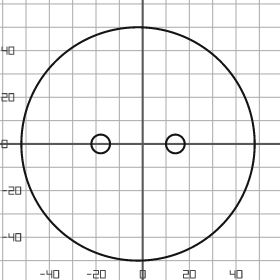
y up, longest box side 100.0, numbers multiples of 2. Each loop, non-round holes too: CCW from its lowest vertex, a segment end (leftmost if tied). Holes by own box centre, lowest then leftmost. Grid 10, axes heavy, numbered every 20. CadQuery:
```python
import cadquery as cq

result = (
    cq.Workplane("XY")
    .moveTo(-2.0, 0.0)
    .circle(50.0)
    .moveTo(-18.0, 0.0)
    .circle(4.0)
    .moveTo(14.0, 0.0)
    .circle(4.0)
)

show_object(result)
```